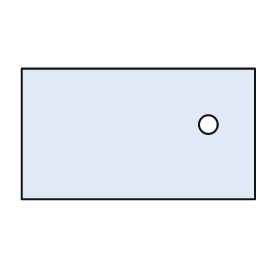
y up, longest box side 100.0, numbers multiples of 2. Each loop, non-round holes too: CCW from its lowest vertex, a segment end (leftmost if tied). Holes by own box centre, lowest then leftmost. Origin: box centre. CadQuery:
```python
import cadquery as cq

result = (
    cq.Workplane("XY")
    .moveTo(-50.0, -28.0)
    .lineTo(50.0, -28.0)
    .lineTo(50.0, 28.0)
    .lineTo(-50.0, 28.0)
    .close()
    .moveTo(30.0, 4.0)
    .circle(4.0)
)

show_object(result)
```